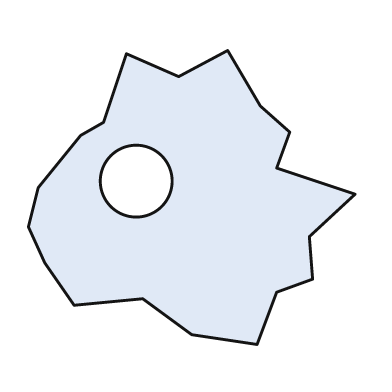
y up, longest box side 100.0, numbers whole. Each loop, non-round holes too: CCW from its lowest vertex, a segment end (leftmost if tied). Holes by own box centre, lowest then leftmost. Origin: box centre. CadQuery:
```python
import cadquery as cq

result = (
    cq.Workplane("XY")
    .moveTo(20.0, -45.0)
    .lineTo(26.0, -29.0)
    .lineTo(37.0, -25.0)
    .lineTo(36.0, -12.0)
    .lineTo(50.0, 1.0)
    .lineTo(26.0, 9.0)
    .lineTo(30.0, 20.0)
    .lineTo(21.0, 28.0)
    .lineTo(11.0, 45.0)
    .lineTo(-4.0, 37.0)
    .lineTo(-20.0, 44.0)
    .lineTo(-27.0, 23.0)
    .lineTo(-34.0, 19.0)
    .lineTo(-47.0, 3.0)
    .lineTo(-50.0, -9.0)
    .lineTo(-45.0, -20.0)
    .lineTo(-36.0, -33.0)
    .lineTo(-15.0, -31.0)
    .lineTo(0.0, -42.0)
    .close()
    .moveTo(-17.0, 5.0)
    .circle(11.0)
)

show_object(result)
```